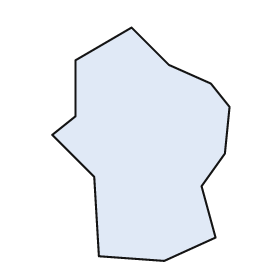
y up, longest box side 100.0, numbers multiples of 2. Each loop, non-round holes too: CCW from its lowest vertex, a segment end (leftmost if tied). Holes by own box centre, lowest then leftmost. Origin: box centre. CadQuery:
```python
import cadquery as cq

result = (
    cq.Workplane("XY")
    .moveTo(10.0, -50.0)
    .lineTo(32.0, -40.0)
    .lineTo(26.0, -18.0)
    .lineTo(36.0, -4.0)
    .lineTo(38.0, 16.0)
    .lineTo(30.0, 26.0)
    .lineTo(12.0, 34.0)
    .lineTo(-4.0, 50.0)
    .lineTo(-28.0, 36.0)
    .lineTo(-28.0, 12.0)
    .lineTo(-38.0, 4.0)
    .lineTo(-20.0, -14.0)
    .lineTo(-18.0, -48.0)
    .close()
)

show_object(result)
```